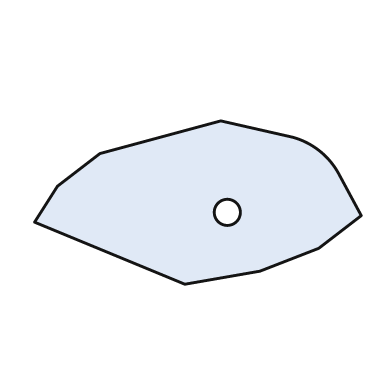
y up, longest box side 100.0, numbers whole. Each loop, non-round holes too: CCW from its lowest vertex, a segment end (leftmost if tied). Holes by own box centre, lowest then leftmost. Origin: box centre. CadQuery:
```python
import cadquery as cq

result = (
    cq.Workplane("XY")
    .moveTo(-4.0, -25.0)
    .lineTo(19.0, -21.0)
    .lineTo(37.0, -14.0)
    .lineTo(50.0, -4.0)
    .lineTo(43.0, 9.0)
    .threePointArc((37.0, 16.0), (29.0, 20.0))
    .lineTo(7.0, 25.0)
    .lineTo(-30.0, 15.0)
    .lineTo(-43.0, 5.0)
    .lineTo(-50.0, -6.0)
    .close()
    .moveTo(9.0, -3.0)
    .circle(4.0)
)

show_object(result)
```